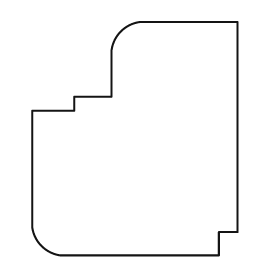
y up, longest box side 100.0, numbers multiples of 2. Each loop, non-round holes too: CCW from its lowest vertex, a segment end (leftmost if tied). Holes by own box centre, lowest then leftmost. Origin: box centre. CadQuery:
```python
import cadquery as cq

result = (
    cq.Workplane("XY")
    .moveTo(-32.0, -50.0)
    .lineTo(36.0, -50.0)
    .lineTo(36.0, -40.0)
    .lineTo(44.0, -40.0)
    .lineTo(44.0, 50.0)
    .lineTo(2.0, 50.0)
    .threePointArc((-6.0, 46.0), (-10.0, 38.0))
    .lineTo(-10.0, 18.0)
    .lineTo(-26.0, 18.0)
    .lineTo(-26.0, 12.0)
    .lineTo(-44.0, 12.0)
    .lineTo(-44.0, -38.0)
    .threePointArc((-40.0, -46.0), (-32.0, -50.0))
    .close()
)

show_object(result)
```